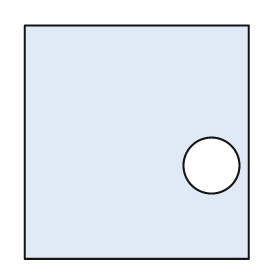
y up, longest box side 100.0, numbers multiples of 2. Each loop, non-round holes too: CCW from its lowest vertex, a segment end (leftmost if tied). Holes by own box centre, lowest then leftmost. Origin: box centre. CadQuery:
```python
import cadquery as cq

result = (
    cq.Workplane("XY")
    .moveTo(-48.0, -50.0)
    .lineTo(48.0, -50.0)
    .lineTo(48.0, 50.0)
    .lineTo(-48.0, 50.0)
    .close()
    .moveTo(32.0, -10.0)
    .circle(12.0)
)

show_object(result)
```